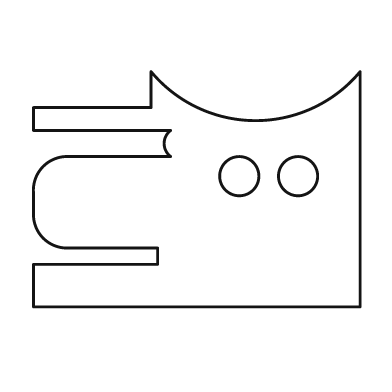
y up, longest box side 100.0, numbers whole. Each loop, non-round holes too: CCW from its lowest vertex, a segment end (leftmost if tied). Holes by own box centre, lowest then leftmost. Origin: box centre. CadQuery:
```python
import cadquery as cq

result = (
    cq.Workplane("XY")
    .moveTo(-50.0, -36.0)
    .lineTo(50.0, -36.0)
    .lineTo(50.0, 36.0)
    .threePointArc((18.0, 21.0), (-14.0, 36.0))
    .lineTo(-14.0, 25.0)
    .lineTo(-50.0, 25.0)
    .lineTo(-50.0, 18.0)
    .lineTo(-8.0, 18.0)
    .threePointArc((-10.0, 14.0), (-8.0, 10.0))
    .lineTo(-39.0, 10.0)
    .threePointArc((-47.0, 7.0), (-50.0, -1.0))
    .lineTo(-50.0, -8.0)
    .threePointArc((-47.0, -15.0), (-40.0, -18.0))
    .lineTo(-12.0, -18.0)
    .lineTo(-12.0, -23.0)
    .lineTo(-50.0, -23.0)
    .close()
    .moveTo(13.0, 4.0)
    .circle(6.0)
    .moveTo(31.0, 4.0)
    .circle(6.0)
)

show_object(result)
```